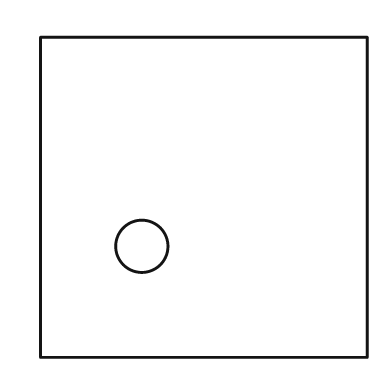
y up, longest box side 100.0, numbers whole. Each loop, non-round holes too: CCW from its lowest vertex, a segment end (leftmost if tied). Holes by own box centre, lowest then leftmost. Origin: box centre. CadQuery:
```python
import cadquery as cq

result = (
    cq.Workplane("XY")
    .moveTo(-50.0, -49.0)
    .lineTo(50.0, -49.0)
    .lineTo(50.0, 49.0)
    .lineTo(-50.0, 49.0)
    .close()
    .moveTo(-19.0, -15.0)
    .circle(8.0)
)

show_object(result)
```